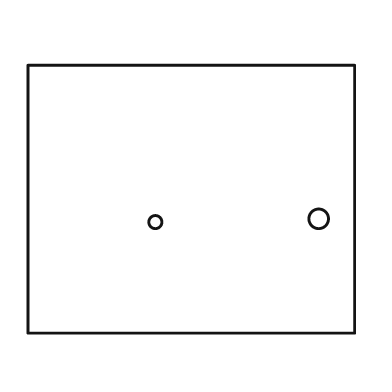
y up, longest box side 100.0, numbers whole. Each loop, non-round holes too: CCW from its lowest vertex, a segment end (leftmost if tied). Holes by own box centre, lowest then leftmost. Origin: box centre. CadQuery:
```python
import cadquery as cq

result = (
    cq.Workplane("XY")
    .moveTo(-50.0, -41.0)
    .lineTo(50.0, -41.0)
    .lineTo(50.0, 41.0)
    .lineTo(-50.0, 41.0)
    .close()
    .moveTo(-11.0, -7.0)
    .circle(2.0)
    .moveTo(39.0, -6.0)
    .circle(3.0)
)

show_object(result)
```